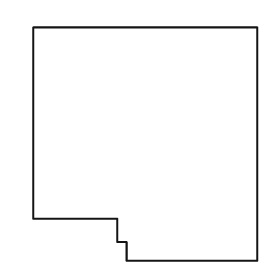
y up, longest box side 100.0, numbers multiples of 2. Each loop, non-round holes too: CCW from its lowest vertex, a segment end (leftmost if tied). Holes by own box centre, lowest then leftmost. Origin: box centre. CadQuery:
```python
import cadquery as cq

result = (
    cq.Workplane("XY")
    .moveTo(-8.0, -50.0)
    .lineTo(48.0, -50.0)
    .lineTo(48.0, 50.0)
    .lineTo(-48.0, 50.0)
    .lineTo(-48.0, -32.0)
    .lineTo(-12.0, -32.0)
    .lineTo(-12.0, -42.0)
    .lineTo(-8.0, -42.0)
    .close()
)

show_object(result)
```